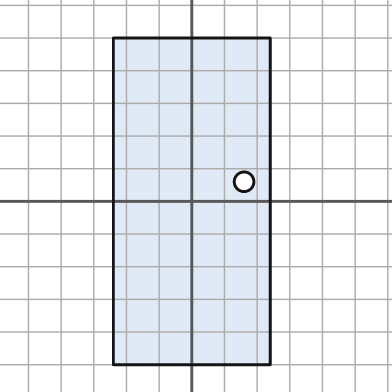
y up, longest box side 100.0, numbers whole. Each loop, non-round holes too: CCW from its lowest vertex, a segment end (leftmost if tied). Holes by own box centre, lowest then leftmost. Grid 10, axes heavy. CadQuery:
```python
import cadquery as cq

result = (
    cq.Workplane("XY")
    .moveTo(-24.0, -50.0)
    .lineTo(24.0, -50.0)
    .lineTo(24.0, 50.0)
    .lineTo(-24.0, 50.0)
    .close()
    .moveTo(16.0, 6.0)
    .circle(3.0)
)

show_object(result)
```